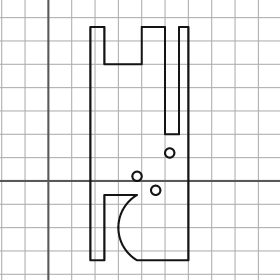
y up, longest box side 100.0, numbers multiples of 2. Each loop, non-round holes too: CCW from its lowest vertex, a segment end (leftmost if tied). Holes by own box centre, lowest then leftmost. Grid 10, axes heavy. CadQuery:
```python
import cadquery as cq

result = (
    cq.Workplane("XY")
    .moveTo(18.0, -34.0)
    .lineTo(24.0, -34.0)
    .lineTo(24.0, -6.0)
    .lineTo(38.0, -6.0)
    .threePointArc((30.0, -20.0), (38.0, -34.0))
    .lineTo(60.0, -34.0)
    .lineTo(60.0, 66.0)
    .lineTo(56.0, 66.0)
    .lineTo(56.0, 20.0)
    .lineTo(50.0, 20.0)
    .lineTo(50.0, 66.0)
    .lineTo(40.0, 66.0)
    .lineTo(40.0, 50.0)
    .lineTo(24.0, 50.0)
    .lineTo(24.0, 66.0)
    .lineTo(18.0, 66.0)
    .close()
    .moveTo(46.0, -4.0)
    .circle(2.0)
    .moveTo(38.0, 2.0)
    .circle(2.0)
    .moveTo(52.0, 12.0)
    .circle(2.0)
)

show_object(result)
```